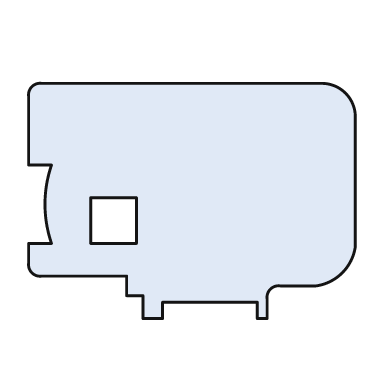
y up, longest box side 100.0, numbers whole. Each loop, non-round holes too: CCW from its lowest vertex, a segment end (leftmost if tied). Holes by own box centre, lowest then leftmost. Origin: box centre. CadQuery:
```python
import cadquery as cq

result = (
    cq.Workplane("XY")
    .moveTo(-15.0, -36.0)
    .lineTo(-9.0, -36.0)
    .lineTo(-9.0, -31.0)
    .lineTo(20.0, -31.0)
    .lineTo(20.0, -36.0)
    .lineTo(23.0, -36.0)
    .lineTo(23.0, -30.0)
    .threePointArc((24.0, -27.0), (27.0, -26.0))
    .lineTo(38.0, -26.0)
    .threePointArc((46.0, -22.0), (50.0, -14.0))
    .lineTo(50.0, 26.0)
    .threePointArc((47.0, 33.0), (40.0, 36.0))
    .lineTo(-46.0, 36.0)
    .threePointArc((-49.0, 35.0), (-50.0, 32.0))
    .lineTo(-50.0, 11.0)
    .lineTo(-43.0, 11.0)
    .threePointArc((-45.0, -1.0), (-43.0, -13.0))
    .lineTo(-50.0, -13.0)
    .lineTo(-50.0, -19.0)
    .threePointArc((-49.0, -22.0), (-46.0, -23.0))
    .lineTo(-20.0, -23.0)
    .lineTo(-20.0, -29.0)
    .lineTo(-15.0, -29.0)
    .close()
    .moveTo(-31.0, -13.0)
    .lineTo(-17.0, -13.0)
    .lineTo(-17.0, 1.0)
    .lineTo(-31.0, 1.0)
    .close()
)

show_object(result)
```